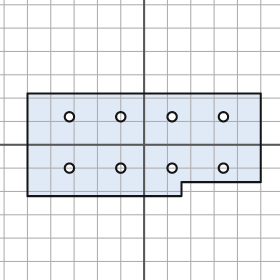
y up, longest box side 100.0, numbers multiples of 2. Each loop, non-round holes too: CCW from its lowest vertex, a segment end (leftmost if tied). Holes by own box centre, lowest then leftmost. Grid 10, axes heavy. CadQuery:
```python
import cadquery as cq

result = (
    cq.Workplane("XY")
    .moveTo(-50.0, -22.0)
    .lineTo(16.0, -22.0)
    .lineTo(16.0, -16.0)
    .lineTo(50.0, -16.0)
    .lineTo(50.0, 22.0)
    .lineTo(-50.0, 22.0)
    .close()
    .moveTo(-32.0, -10.0)
    .circle(2.0)
    .moveTo(-10.0, -10.0)
    .circle(2.0)
    .moveTo(12.0, -10.0)
    .circle(2.0)
    .moveTo(34.0, -10.0)
    .circle(2.0)
    .moveTo(-32.0, 12.0)
    .circle(2.0)
    .moveTo(-10.0, 12.0)
    .circle(2.0)
    .moveTo(12.0, 12.0)
    .circle(2.0)
    .moveTo(34.0, 12.0)
    .circle(2.0)
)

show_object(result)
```